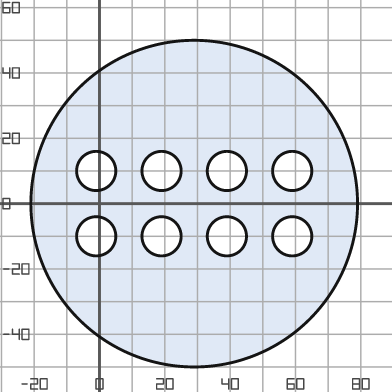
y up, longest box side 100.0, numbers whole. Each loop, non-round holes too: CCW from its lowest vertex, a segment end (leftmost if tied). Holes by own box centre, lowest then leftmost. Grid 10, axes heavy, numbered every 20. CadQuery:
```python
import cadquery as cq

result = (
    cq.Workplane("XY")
    .moveTo(29.0, 0.0)
    .circle(50.0)
    .moveTo(-1.0, -10.0)
    .circle(6.0)
    .moveTo(19.0, -10.0)
    .circle(6.0)
    .moveTo(39.0, -10.0)
    .circle(6.0)
    .moveTo(59.0, -10.0)
    .circle(6.0)
    .moveTo(-1.0, 10.0)
    .circle(6.0)
    .moveTo(19.0, 10.0)
    .circle(6.0)
    .moveTo(39.0, 10.0)
    .circle(6.0)
    .moveTo(59.0, 10.0)
    .circle(6.0)
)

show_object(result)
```